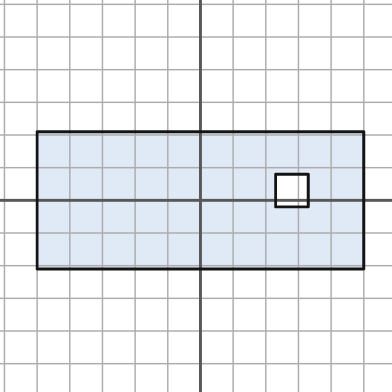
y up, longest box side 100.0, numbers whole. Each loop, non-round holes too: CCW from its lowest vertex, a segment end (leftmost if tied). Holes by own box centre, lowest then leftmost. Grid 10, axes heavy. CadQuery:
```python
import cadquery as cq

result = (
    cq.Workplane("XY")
    .moveTo(-50.0, -21.0)
    .lineTo(50.0, -21.0)
    .lineTo(50.0, 21.0)
    .lineTo(-50.0, 21.0)
    .close()
    .moveTo(23.0, -2.0)
    .lineTo(33.0, -2.0)
    .lineTo(33.0, 8.0)
    .lineTo(23.0, 8.0)
    .close()
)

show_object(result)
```